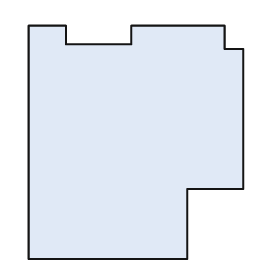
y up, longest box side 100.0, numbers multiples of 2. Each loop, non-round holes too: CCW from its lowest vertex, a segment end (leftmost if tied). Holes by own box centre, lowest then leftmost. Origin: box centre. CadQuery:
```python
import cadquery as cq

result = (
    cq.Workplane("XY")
    .moveTo(-46.0, -50.0)
    .lineTo(22.0, -50.0)
    .lineTo(22.0, -20.0)
    .lineTo(46.0, -20.0)
    .lineTo(46.0, 40.0)
    .lineTo(38.0, 40.0)
    .lineTo(38.0, 50.0)
    .lineTo(-2.0, 50.0)
    .lineTo(-2.0, 42.0)
    .lineTo(-30.0, 42.0)
    .lineTo(-30.0, 50.0)
    .lineTo(-46.0, 50.0)
    .close()
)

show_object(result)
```